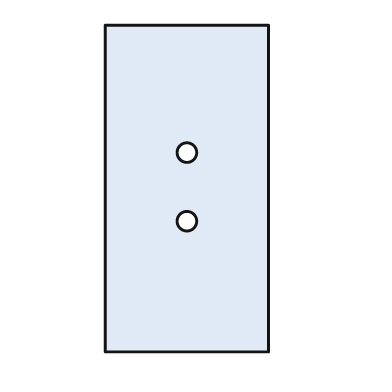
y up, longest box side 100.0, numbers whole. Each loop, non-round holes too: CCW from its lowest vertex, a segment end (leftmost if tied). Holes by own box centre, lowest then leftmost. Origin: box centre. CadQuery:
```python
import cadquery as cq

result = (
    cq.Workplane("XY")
    .moveTo(-25.0, -50.0)
    .lineTo(25.0, -50.0)
    .lineTo(25.0, 50.0)
    .lineTo(-25.0, 50.0)
    .close()
    .moveTo(0.0, -10.0)
    .circle(3.0)
    .moveTo(0.0, 11.0)
    .circle(3.0)
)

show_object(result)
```